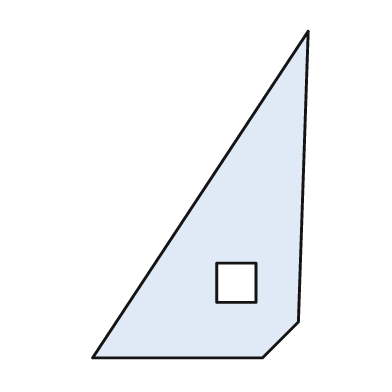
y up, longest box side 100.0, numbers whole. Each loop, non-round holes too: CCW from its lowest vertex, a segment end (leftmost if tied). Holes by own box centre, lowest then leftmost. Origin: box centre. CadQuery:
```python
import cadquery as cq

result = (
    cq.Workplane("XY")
    .moveTo(-33.0, -50.0)
    .lineTo(19.0, -50.0)
    .lineTo(30.0, -39.0)
    .lineTo(33.0, 50.0)
    .close()
    .moveTo(5.0, -33.0)
    .lineTo(17.0, -33.0)
    .lineTo(17.0, -21.0)
    .lineTo(5.0, -21.0)
    .close()
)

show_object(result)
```